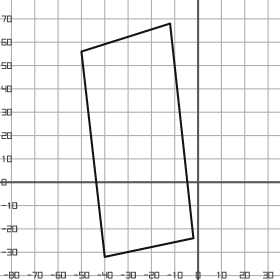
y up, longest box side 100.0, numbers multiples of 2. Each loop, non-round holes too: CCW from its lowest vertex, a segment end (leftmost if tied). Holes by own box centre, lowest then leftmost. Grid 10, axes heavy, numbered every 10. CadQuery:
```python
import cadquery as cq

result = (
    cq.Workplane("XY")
    .moveTo(-40.0, -32.0)
    .lineTo(-2.0, -24.0)
    .lineTo(-12.0, 68.0)
    .lineTo(-50.0, 56.0)
    .close()
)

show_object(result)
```